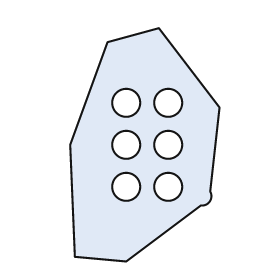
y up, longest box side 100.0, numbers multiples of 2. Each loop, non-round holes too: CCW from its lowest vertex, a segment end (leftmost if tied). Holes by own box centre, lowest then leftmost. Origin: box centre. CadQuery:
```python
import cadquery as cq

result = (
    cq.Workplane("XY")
    .moveTo(-8.0, -50.0)
    .lineTo(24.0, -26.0)
    .threePointArc((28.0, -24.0), (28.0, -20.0))
    .lineTo(32.0, 16.0)
    .lineTo(6.0, 50.0)
    .lineTo(-16.0, 44.0)
    .lineTo(-32.0, 0.0)
    .lineTo(-30.0, -48.0)
    .close()
    .moveTo(-8.0, -18.0)
    .circle(6.0)
    .moveTo(10.0, -18.0)
    .circle(6.0)
    .moveTo(-8.0, 0.0)
    .circle(6.0)
    .moveTo(10.0, 0.0)
    .circle(6.0)
    .moveTo(-8.0, 18.0)
    .circle(6.0)
    .moveTo(10.0, 18.0)
    .circle(6.0)
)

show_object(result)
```